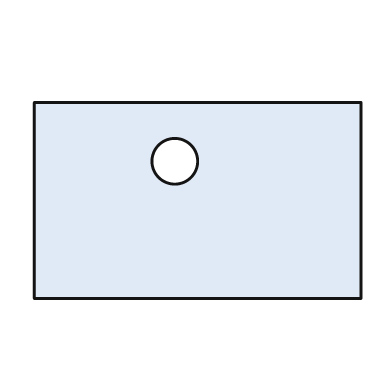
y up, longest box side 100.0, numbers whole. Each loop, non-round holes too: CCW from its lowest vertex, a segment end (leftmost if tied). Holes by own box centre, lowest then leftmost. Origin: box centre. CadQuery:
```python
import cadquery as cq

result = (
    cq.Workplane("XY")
    .moveTo(-50.0, -30.0)
    .lineTo(50.0, -30.0)
    .lineTo(50.0, 30.0)
    .lineTo(-50.0, 30.0)
    .close()
    .moveTo(-7.0, 12.0)
    .circle(7.0)
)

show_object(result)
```